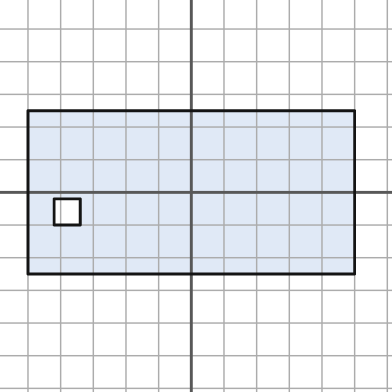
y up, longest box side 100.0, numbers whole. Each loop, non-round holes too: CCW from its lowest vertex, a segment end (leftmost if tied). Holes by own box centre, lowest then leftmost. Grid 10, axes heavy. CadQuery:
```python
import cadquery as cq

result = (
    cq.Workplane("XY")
    .moveTo(-50.0, -25.0)
    .lineTo(50.0, -25.0)
    .lineTo(50.0, 25.0)
    .lineTo(-50.0, 25.0)
    .close()
    .moveTo(-42.0, -10.0)
    .lineTo(-34.0, -10.0)
    .lineTo(-34.0, -2.0)
    .lineTo(-42.0, -2.0)
    .close()
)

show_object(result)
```